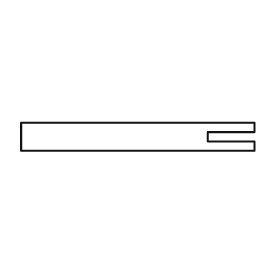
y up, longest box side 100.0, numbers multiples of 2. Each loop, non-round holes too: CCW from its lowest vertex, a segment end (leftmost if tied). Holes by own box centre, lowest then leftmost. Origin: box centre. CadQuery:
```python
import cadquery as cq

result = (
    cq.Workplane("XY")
    .moveTo(-50.0, -6.0)
    .lineTo(50.0, -6.0)
    .lineTo(50.0, -2.0)
    .lineTo(30.0, -2.0)
    .lineTo(30.0, 2.0)
    .lineTo(50.0, 2.0)
    .lineTo(50.0, 6.0)
    .lineTo(-50.0, 6.0)
    .close()
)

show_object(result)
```